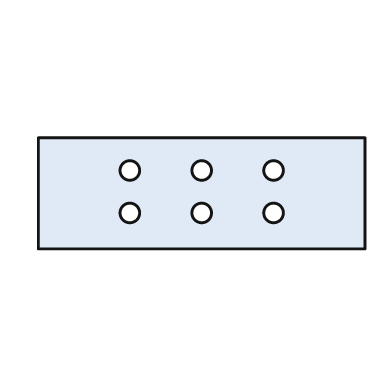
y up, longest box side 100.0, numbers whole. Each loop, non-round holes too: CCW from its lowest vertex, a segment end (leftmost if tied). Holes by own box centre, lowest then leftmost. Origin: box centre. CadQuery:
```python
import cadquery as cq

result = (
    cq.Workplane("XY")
    .moveTo(-50.0, -17.0)
    .lineTo(50.0, -17.0)
    .lineTo(50.0, 17.0)
    .lineTo(-50.0, 17.0)
    .close()
    .moveTo(-22.0, -6.0)
    .circle(3.0)
    .moveTo(0.0, -6.0)
    .circle(3.0)
    .moveTo(22.0, -6.0)
    .circle(3.0)
    .moveTo(-22.0, 7.0)
    .circle(3.0)
    .moveTo(0.0, 7.0)
    .circle(3.0)
    .moveTo(22.0, 7.0)
    .circle(3.0)
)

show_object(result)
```